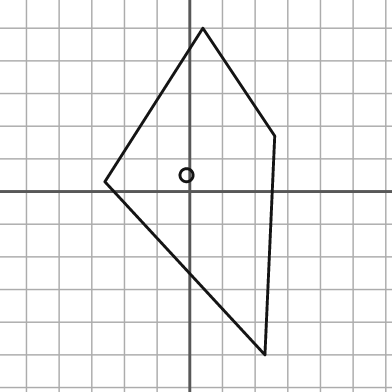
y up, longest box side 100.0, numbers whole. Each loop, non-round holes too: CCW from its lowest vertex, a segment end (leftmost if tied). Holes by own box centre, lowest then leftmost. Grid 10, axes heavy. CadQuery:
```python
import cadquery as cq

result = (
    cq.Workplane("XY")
    .moveTo(23.0, -50.0)
    .lineTo(26.0, 17.0)
    .lineTo(4.0, 50.0)
    .lineTo(-26.0, 3.0)
    .close()
    .moveTo(-1.0, 5.0)
    .circle(2.0)
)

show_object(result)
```